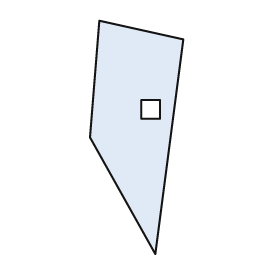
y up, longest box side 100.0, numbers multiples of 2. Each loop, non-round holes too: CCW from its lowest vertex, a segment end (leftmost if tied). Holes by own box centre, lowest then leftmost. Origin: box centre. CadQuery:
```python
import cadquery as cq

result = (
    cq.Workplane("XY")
    .moveTo(8.0, -50.0)
    .lineTo(20.0, 42.0)
    .lineTo(-16.0, 50.0)
    .lineTo(-20.0, 0.0)
    .close()
    .moveTo(2.0, 8.0)
    .lineTo(10.0, 8.0)
    .lineTo(10.0, 16.0)
    .lineTo(2.0, 16.0)
    .close()
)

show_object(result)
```